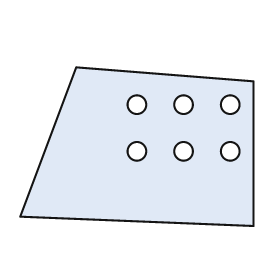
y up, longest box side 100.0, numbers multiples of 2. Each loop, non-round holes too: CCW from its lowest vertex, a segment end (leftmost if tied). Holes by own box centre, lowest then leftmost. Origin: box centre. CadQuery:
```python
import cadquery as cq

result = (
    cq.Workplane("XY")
    .moveTo(50.0, -34.0)
    .lineTo(50.0, 28.0)
    .lineTo(-26.0, 34.0)
    .lineTo(-50.0, -30.0)
    .close()
    .moveTo(0.0, -2.0)
    .circle(4.0)
    .moveTo(20.0, -2.0)
    .circle(4.0)
    .moveTo(40.0, -2.0)
    .circle(4.0)
    .moveTo(0.0, 18.0)
    .circle(4.0)
    .moveTo(20.0, 18.0)
    .circle(4.0)
    .moveTo(40.0, 18.0)
    .circle(4.0)
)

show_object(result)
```